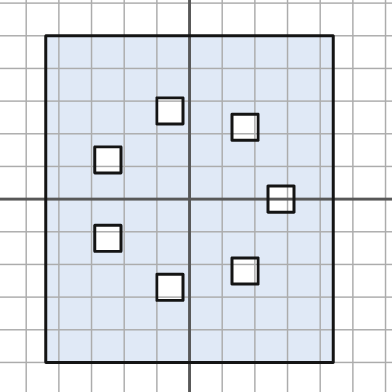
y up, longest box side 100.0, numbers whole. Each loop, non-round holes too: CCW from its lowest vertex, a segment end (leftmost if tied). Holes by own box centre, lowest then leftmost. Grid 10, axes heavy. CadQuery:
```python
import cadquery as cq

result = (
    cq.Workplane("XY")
    .moveTo(-44.0, -50.0)
    .lineTo(44.0, -50.0)
    .lineTo(44.0, 50.0)
    .lineTo(-44.0, 50.0)
    .close()
    .moveTo(-10.0, -31.0)
    .lineTo(-2.0, -31.0)
    .lineTo(-2.0, -23.0)
    .lineTo(-10.0, -23.0)
    .close()
    .moveTo(13.0, -26.0)
    .lineTo(21.0, -26.0)
    .lineTo(21.0, -18.0)
    .lineTo(13.0, -18.0)
    .close()
    .moveTo(-29.0, -16.0)
    .lineTo(-21.0, -16.0)
    .lineTo(-21.0, -8.0)
    .lineTo(-29.0, -8.0)
    .close()
    .moveTo(24.0, -4.0)
    .lineTo(32.0, -4.0)
    .lineTo(32.0, 4.0)
    .lineTo(24.0, 4.0)
    .close()
    .moveTo(-29.0, 8.0)
    .lineTo(-21.0, 8.0)
    .lineTo(-21.0, 16.0)
    .lineTo(-29.0, 16.0)
    .close()
    .moveTo(13.0, 18.0)
    .lineTo(21.0, 18.0)
    .lineTo(21.0, 26.0)
    .lineTo(13.0, 26.0)
    .close()
    .moveTo(-10.0, 23.0)
    .lineTo(-2.0, 23.0)
    .lineTo(-2.0, 31.0)
    .lineTo(-10.0, 31.0)
    .close()
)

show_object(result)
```